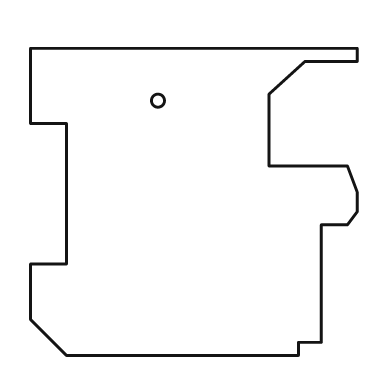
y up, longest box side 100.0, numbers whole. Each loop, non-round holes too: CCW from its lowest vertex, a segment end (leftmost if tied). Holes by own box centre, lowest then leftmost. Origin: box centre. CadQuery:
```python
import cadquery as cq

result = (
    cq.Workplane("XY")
    .moveTo(-39.0, -47.0)
    .lineTo(32.0, -47.0)
    .lineTo(32.0, -43.0)
    .lineTo(39.0, -43.0)
    .lineTo(39.0, -7.0)
    .lineTo(47.0, -7.0)
    .lineTo(50.0, -3.0)
    .lineTo(50.0, 3.0)
    .lineTo(47.0, 11.0)
    .lineTo(23.0, 11.0)
    .lineTo(23.0, 33.0)
    .lineTo(34.0, 43.0)
    .lineTo(50.0, 43.0)
    .lineTo(50.0, 47.0)
    .lineTo(-50.0, 47.0)
    .lineTo(-50.0, 24.0)
    .lineTo(-39.0, 24.0)
    .lineTo(-39.0, -19.0)
    .lineTo(-50.0, -19.0)
    .lineTo(-50.0, -36.0)
    .close()
    .moveTo(-11.0, 31.0)
    .circle(2.0)
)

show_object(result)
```